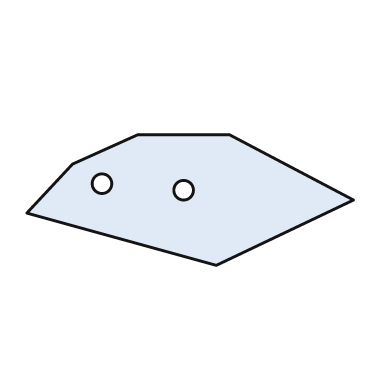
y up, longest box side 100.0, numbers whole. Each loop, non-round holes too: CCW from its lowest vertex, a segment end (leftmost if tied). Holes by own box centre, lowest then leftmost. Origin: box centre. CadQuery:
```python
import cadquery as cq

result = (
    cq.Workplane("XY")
    .moveTo(8.0, -20.0)
    .lineTo(50.0, 0.0)
    .lineTo(12.0, 20.0)
    .lineTo(-16.0, 20.0)
    .lineTo(-36.0, 11.0)
    .lineTo(-50.0, -4.0)
    .close()
    .moveTo(-2.0, 3.0)
    .circle(3.0)
    .moveTo(-27.0, 5.0)
    .circle(3.0)
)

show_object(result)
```